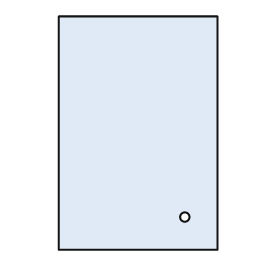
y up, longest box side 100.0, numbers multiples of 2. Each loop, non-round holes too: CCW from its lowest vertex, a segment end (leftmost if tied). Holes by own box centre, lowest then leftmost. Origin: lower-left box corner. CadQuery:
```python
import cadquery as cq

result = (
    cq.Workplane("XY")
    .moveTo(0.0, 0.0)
    .lineTo(68.0, 0.0)
    .lineTo(68.0, 100.0)
    .lineTo(0.0, 100.0)
    .close()
    .moveTo(54.0, 14.0)
    .circle(2.0)
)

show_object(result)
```